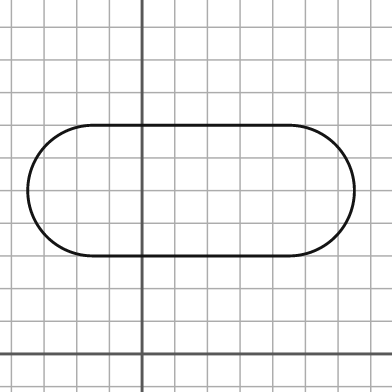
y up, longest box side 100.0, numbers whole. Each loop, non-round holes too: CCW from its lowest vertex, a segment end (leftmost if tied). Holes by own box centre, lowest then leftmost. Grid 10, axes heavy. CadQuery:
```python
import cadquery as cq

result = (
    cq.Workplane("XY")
    .moveTo(-15.0, 30.0)
    .lineTo(45.0, 30.0)
    .threePointArc((65.0, 50.0), (45.0, 70.0))
    .lineTo(-15.0, 70.0)
    .threePointArc((-35.0, 50.0), (-15.0, 30.0))
    .close()
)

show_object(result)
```